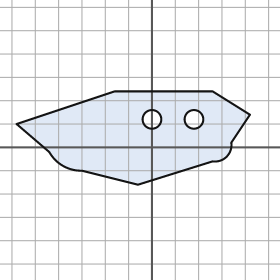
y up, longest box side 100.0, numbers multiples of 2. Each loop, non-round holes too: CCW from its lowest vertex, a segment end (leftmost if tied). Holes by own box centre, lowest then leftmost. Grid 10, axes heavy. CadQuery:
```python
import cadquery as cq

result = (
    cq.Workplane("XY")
    .moveTo(-6.0, -16.0)
    .lineTo(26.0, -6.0)
    .threePointArc((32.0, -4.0), (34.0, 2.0))
    .lineTo(42.0, 14.0)
    .lineTo(26.0, 24.0)
    .lineTo(-16.0, 24.0)
    .lineTo(-58.0, 10.0)
    .lineTo(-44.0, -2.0)
    .threePointArc((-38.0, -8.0), (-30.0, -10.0))
    .close()
    .moveTo(0.0, 12.0)
    .circle(4.0)
    .moveTo(18.0, 12.0)
    .circle(4.0)
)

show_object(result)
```